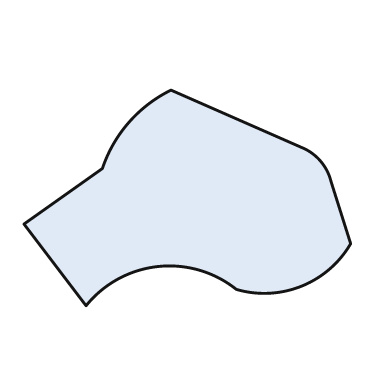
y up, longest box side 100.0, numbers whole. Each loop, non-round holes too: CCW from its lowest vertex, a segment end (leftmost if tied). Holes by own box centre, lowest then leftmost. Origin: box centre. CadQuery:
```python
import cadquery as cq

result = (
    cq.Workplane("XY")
    .moveTo(-31.0, -33.0)
    .threePointArc((-9.0, -21.0), (15.0, -28.0))
    .threePointArc((35.0, -27.0), (50.0, -14.0))
    .lineTo(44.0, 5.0)
    .threePointArc((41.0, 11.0), (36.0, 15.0))
    .lineTo(-5.0, 33.0)
    .threePointArc((-18.0, 23.0), (-26.0, 9.0))
    .lineTo(-50.0, -8.0)
    .close()
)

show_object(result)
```